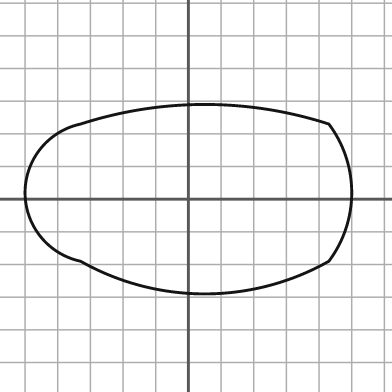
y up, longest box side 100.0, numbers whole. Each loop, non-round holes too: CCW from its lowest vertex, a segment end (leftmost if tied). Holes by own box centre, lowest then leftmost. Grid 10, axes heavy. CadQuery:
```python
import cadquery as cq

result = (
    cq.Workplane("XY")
    .moveTo(-33.0, -19.0)
    .threePointArc((5.0, -29.0), (43.0, -19.0))
    .threePointArc((50.0, 2.0), (43.0, 23.0))
    .threePointArc((5.0, 29.0), (-33.0, 23.0))
    .threePointArc((-50.0, 2.0), (-33.0, -19.0))
    .close()
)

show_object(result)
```